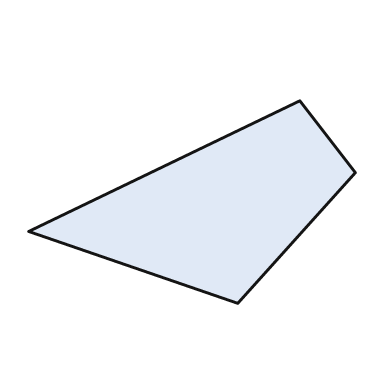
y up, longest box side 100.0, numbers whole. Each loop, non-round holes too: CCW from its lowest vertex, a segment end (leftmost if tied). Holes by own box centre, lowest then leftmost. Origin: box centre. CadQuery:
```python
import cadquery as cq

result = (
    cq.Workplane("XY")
    .moveTo(14.0, -31.0)
    .lineTo(50.0, 9.0)
    .lineTo(33.0, 31.0)
    .lineTo(-50.0, -9.0)
    .close()
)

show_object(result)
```